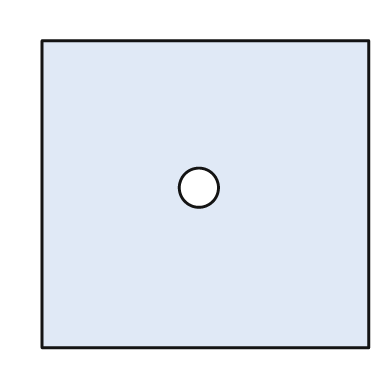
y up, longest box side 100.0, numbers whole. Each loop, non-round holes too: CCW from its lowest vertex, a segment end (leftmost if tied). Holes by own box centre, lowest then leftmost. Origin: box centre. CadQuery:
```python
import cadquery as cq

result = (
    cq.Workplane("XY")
    .moveTo(-50.0, -47.0)
    .lineTo(50.0, -47.0)
    .lineTo(50.0, 47.0)
    .lineTo(-50.0, 47.0)
    .close()
    .moveTo(-2.0, 2.0)
    .circle(6.0)
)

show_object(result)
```